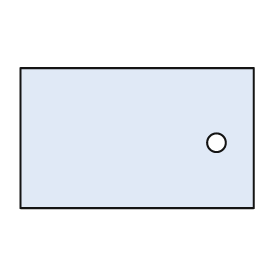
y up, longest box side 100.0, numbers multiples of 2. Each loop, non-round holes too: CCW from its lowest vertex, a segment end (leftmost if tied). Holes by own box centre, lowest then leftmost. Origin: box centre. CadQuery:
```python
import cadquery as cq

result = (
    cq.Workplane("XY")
    .moveTo(-50.0, -30.0)
    .lineTo(50.0, -30.0)
    .lineTo(50.0, 30.0)
    .lineTo(-50.0, 30.0)
    .close()
    .moveTo(34.0, -2.0)
    .circle(4.0)
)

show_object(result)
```